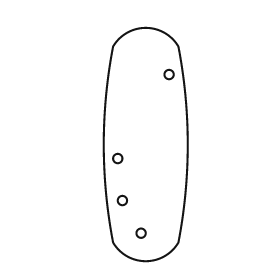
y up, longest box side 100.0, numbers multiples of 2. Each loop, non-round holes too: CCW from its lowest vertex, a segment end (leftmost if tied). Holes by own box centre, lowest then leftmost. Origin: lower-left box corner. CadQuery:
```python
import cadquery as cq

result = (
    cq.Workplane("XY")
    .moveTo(4.0, 8.0)
    .threePointArc((18.0, 0.0), (32.0, 8.0))
    .threePointArc((36.0, 50.0), (32.0, 92.0))
    .threePointArc((18.0, 100.0), (4.0, 92.0))
    .threePointArc((0.0, 50.0), (4.0, 8.0))
    .close()
    .moveTo(16.0, 12.0)
    .circle(2.0)
    .moveTo(8.0, 26.0)
    .circle(2.0)
    .moveTo(6.0, 44.0)
    .circle(2.0)
    .moveTo(28.0, 80.0)
    .circle(2.0)
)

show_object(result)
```